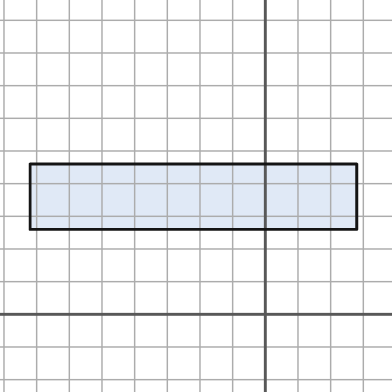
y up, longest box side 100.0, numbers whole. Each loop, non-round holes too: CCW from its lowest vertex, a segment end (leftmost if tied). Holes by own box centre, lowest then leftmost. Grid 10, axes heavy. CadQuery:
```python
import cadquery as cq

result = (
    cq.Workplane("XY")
    .moveTo(-72.0, 26.0)
    .lineTo(28.0, 26.0)
    .lineTo(28.0, 46.0)
    .lineTo(-72.0, 46.0)
    .close()
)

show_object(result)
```